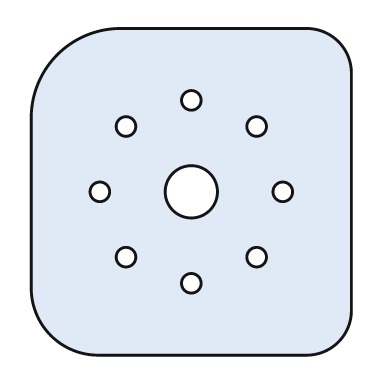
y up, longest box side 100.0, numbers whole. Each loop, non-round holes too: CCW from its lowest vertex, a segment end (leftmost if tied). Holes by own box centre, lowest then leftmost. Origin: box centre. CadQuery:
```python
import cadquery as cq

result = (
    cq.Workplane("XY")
    .moveTo(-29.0, -50.0)
    .lineTo(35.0, -50.0)
    .threePointArc((45.0, -46.0), (49.0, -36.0))
    .lineTo(49.0, 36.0)
    .threePointArc((45.0, 46.0), (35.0, 50.0))
    .lineTo(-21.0, 50.0)
    .threePointArc((-41.0, 42.0), (-49.0, 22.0))
    .lineTo(-49.0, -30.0)
    .threePointArc((-43.0, -44.0), (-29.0, -50.0))
    .close()
    .moveTo(0.0, -28.0)
    .circle(3.0)
    .moveTo(-20.0, -20.0)
    .circle(3.0)
    .moveTo(20.0, -20.0)
    .circle(3.0)
    .moveTo(-28.0, 0.0)
    .circle(3.0)
    .moveTo(0.0, 0.0)
    .circle(8.0)
    .moveTo(28.0, 0.0)
    .circle(3.0)
    .moveTo(-20.0, 20.0)
    .circle(3.0)
    .moveTo(20.0, 20.0)
    .circle(3.0)
    .moveTo(0.0, 28.0)
    .circle(3.0)
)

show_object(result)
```